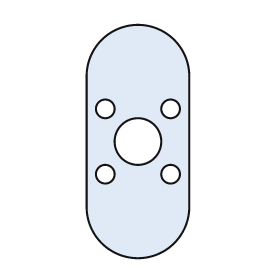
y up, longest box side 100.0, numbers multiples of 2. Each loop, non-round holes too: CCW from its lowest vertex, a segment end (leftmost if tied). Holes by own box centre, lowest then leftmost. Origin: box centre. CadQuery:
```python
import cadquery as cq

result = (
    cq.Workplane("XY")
    .moveTo(-22.0, -28.0)
    .threePointArc((0.0, -50.0), (22.0, -28.0))
    .lineTo(22.0, 28.0)
    .threePointArc((0.0, 50.0), (-22.0, 28.0))
    .close()
    .moveTo(-14.0, -14.0)
    .circle(4.0)
    .moveTo(14.0, -14.0)
    .circle(4.0)
    .moveTo(0.0, 0.0)
    .circle(10.0)
    .moveTo(-14.0, 14.0)
    .circle(4.0)
    .moveTo(14.0, 14.0)
    .circle(4.0)
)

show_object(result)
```